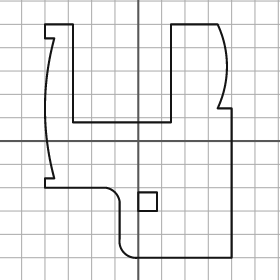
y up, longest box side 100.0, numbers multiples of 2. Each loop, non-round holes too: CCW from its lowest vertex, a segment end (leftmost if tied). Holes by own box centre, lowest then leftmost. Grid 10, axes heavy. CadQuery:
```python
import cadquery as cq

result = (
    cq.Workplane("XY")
    .moveTo(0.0, -50.0)
    .lineTo(40.0, -50.0)
    .lineTo(40.0, 14.0)
    .lineTo(34.0, 14.0)
    .threePointArc((38.0, 32.0), (34.0, 50.0))
    .lineTo(14.0, 50.0)
    .lineTo(14.0, 8.0)
    .lineTo(-28.0, 8.0)
    .lineTo(-28.0, 50.0)
    .lineTo(-40.0, 50.0)
    .lineTo(-40.0, 44.0)
    .lineTo(-36.0, 44.0)
    .threePointArc((-40.0, 14.0), (-36.0, -16.0))
    .lineTo(-40.0, -16.0)
    .lineTo(-40.0, -20.0)
    .lineTo(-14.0, -20.0)
    .threePointArc((-10.0, -22.0), (-8.0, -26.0))
    .lineTo(-8.0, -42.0)
    .threePointArc((-6.0, -48.0), (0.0, -50.0))
    .close()
    .moveTo(0.0, -30.0)
    .lineTo(8.0, -30.0)
    .lineTo(8.0, -22.0)
    .lineTo(0.0, -22.0)
    .close()
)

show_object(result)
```